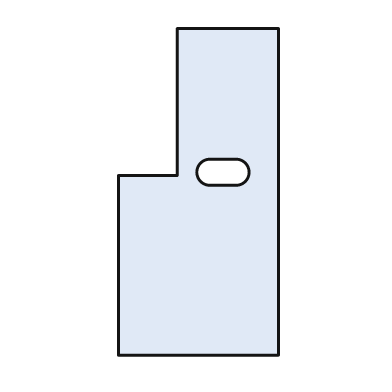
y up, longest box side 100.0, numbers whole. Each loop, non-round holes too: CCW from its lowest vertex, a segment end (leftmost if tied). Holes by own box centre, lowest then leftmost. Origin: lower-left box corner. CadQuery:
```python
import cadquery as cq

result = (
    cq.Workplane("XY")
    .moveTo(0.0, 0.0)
    .lineTo(49.0, 0.0)
    .lineTo(49.0, 100.0)
    .lineTo(18.0, 100.0)
    .lineTo(18.0, 55.0)
    .lineTo(0.0, 55.0)
    .close()
    .moveTo(28.0, 52.0)
    .lineTo(36.0, 52.0)
    .threePointArc((40.0, 56.0), (36.0, 60.0))
    .lineTo(28.0, 60.0)
    .threePointArc((24.0, 56.0), (28.0, 52.0))
    .close()
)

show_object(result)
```